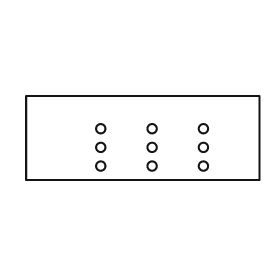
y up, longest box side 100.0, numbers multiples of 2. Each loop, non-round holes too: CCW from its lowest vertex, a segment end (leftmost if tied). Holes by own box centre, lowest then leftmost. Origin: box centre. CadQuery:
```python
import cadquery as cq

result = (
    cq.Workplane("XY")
    .moveTo(-50.0, -18.0)
    .lineTo(50.0, -18.0)
    .lineTo(50.0, 18.0)
    .lineTo(-50.0, 18.0)
    .close()
    .moveTo(-18.0, -12.0)
    .circle(2.0)
    .moveTo(4.0, -12.0)
    .circle(2.0)
    .moveTo(26.0, -12.0)
    .circle(2.0)
    .moveTo(-18.0, -4.0)
    .circle(2.0)
    .moveTo(4.0, -4.0)
    .circle(2.0)
    .moveTo(26.0, -4.0)
    .circle(2.0)
    .moveTo(-18.0, 4.0)
    .circle(2.0)
    .moveTo(4.0, 4.0)
    .circle(2.0)
    .moveTo(26.0, 4.0)
    .circle(2.0)
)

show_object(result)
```